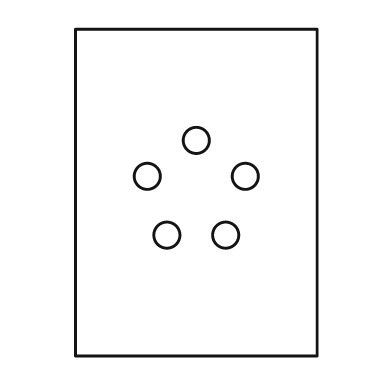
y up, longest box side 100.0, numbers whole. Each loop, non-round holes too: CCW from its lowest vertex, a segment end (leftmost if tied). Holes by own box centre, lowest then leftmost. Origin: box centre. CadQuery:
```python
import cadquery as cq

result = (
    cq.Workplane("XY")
    .moveTo(-37.0, -50.0)
    .lineTo(37.0, -50.0)
    .lineTo(37.0, 50.0)
    .lineTo(-37.0, 50.0)
    .close()
    .moveTo(-9.0, -13.0)
    .circle(4.0)
    .moveTo(9.0, -13.0)
    .circle(4.0)
    .moveTo(-15.0, 5.0)
    .circle(4.0)
    .moveTo(15.0, 5.0)
    .circle(4.0)
    .moveTo(0.0, 16.0)
    .circle(4.0)
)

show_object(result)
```